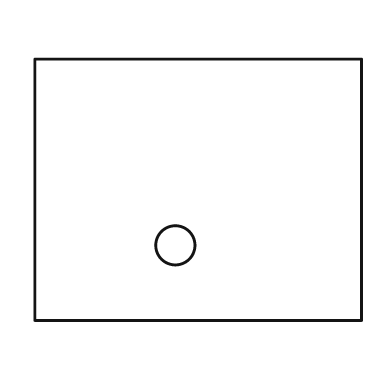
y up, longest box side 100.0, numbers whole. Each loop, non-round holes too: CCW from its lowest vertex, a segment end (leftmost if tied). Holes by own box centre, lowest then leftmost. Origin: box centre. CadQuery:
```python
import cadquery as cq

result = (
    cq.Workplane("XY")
    .moveTo(-50.0, -40.0)
    .lineTo(50.0, -40.0)
    .lineTo(50.0, 40.0)
    .lineTo(-50.0, 40.0)
    .close()
    .moveTo(-7.0, -17.0)
    .circle(6.0)
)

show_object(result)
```